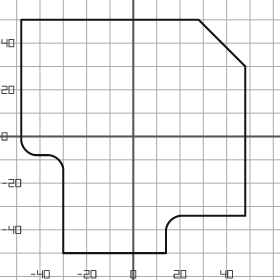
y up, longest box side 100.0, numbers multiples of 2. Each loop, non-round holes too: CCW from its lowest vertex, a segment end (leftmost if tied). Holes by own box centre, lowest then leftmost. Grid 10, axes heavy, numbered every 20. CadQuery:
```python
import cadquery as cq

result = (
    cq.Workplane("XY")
    .moveTo(-30.0, -50.0)
    .lineTo(14.0, -50.0)
    .lineTo(14.0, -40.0)
    .threePointArc((16.0, -36.0), (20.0, -34.0))
    .lineTo(48.0, -34.0)
    .lineTo(48.0, 30.0)
    .lineTo(28.0, 50.0)
    .lineTo(-48.0, 50.0)
    .lineTo(-48.0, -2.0)
    .threePointArc((-46.0, -6.0), (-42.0, -8.0))
    .lineTo(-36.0, -8.0)
    .threePointArc((-32.0, -10.0), (-30.0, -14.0))
    .close()
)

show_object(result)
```